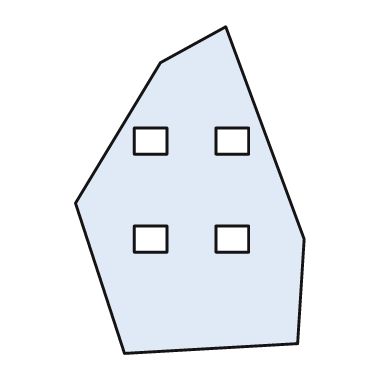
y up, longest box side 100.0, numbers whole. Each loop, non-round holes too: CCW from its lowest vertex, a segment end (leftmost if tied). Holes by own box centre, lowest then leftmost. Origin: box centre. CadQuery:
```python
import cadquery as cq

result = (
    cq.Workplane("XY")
    .moveTo(-20.0, -50.0)
    .lineTo(33.0, -47.0)
    .lineTo(35.0, -15.0)
    .lineTo(11.0, 50.0)
    .lineTo(-9.0, 39.0)
    .lineTo(-35.0, -4.0)
    .close()
    .moveTo(-17.0, -19.0)
    .lineTo(-7.0, -19.0)
    .lineTo(-7.0, -11.0)
    .lineTo(-17.0, -11.0)
    .close()
    .moveTo(8.0, -19.0)
    .lineTo(18.0, -19.0)
    .lineTo(18.0, -11.0)
    .lineTo(8.0, -11.0)
    .close()
    .moveTo(-17.0, 11.0)
    .lineTo(-7.0, 11.0)
    .lineTo(-7.0, 19.0)
    .lineTo(-17.0, 19.0)
    .close()
    .moveTo(8.0, 11.0)
    .lineTo(18.0, 11.0)
    .lineTo(18.0, 19.0)
    .lineTo(8.0, 19.0)
    .close()
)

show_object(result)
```